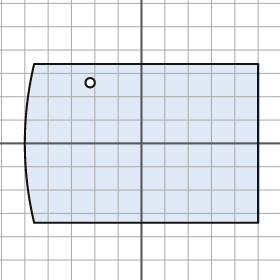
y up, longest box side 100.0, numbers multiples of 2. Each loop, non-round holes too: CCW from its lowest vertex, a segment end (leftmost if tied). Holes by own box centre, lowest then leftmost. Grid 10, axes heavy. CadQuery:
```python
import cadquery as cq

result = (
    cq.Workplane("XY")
    .moveTo(-46.0, -34.0)
    .lineTo(50.0, -34.0)
    .lineTo(50.0, 34.0)
    .lineTo(-46.0, 34.0)
    .threePointArc((-50.0, 0.0), (-46.0, -34.0))
    .close()
    .moveTo(-22.0, 26.0)
    .circle(2.0)
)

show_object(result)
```